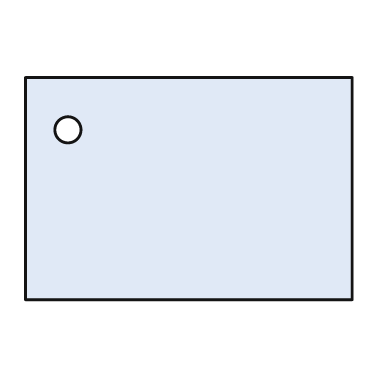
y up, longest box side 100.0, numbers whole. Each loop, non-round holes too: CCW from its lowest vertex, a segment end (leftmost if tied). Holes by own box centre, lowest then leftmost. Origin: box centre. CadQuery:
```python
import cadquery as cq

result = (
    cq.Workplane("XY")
    .moveTo(-50.0, -34.0)
    .lineTo(50.0, -34.0)
    .lineTo(50.0, 34.0)
    .lineTo(-50.0, 34.0)
    .close()
    .moveTo(-37.0, 18.0)
    .circle(4.0)
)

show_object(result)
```